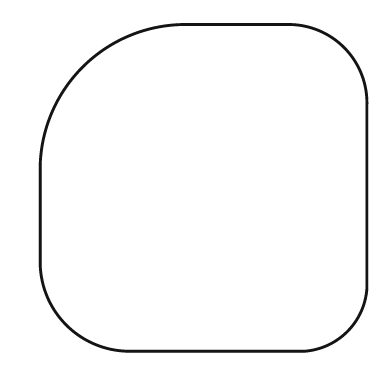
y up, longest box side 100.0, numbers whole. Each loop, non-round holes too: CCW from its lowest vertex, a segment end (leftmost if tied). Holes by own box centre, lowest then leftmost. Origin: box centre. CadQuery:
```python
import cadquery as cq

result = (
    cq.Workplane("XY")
    .moveTo(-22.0, -50.0)
    .lineTo(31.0, -50.0)
    .threePointArc((44.0, -44.0), (50.0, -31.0))
    .lineTo(50.0, 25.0)
    .threePointArc((43.0, 43.0), (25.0, 50.0))
    .lineTo(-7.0, 50.0)
    .threePointArc((-37.0, 37.0), (-50.0, 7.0))
    .lineTo(-50.0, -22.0)
    .threePointArc((-42.0, -42.0), (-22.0, -50.0))
    .close()
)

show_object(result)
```